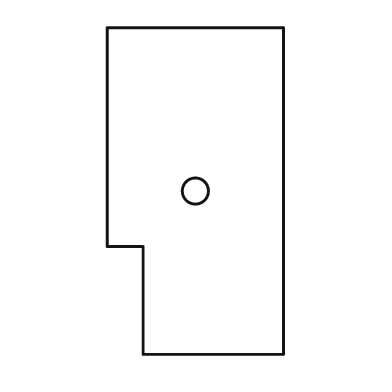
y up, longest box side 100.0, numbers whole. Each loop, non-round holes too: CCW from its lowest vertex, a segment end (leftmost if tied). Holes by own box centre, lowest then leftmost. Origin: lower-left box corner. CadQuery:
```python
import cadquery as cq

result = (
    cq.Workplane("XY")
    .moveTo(11.0, 0.0)
    .lineTo(54.0, 0.0)
    .lineTo(54.0, 100.0)
    .lineTo(0.0, 100.0)
    .lineTo(0.0, 33.0)
    .lineTo(11.0, 33.0)
    .close()
    .moveTo(27.0, 50.0)
    .circle(4.0)
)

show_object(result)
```